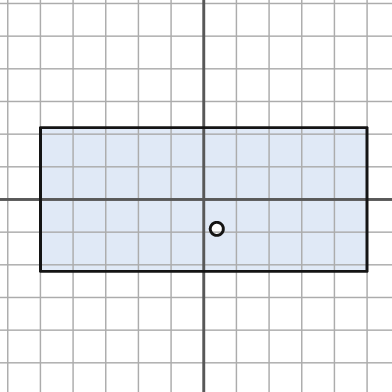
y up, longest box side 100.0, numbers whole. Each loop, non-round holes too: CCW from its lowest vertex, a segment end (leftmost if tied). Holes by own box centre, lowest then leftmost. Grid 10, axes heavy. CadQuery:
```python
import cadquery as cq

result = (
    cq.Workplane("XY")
    .moveTo(-50.0, -22.0)
    .lineTo(50.0, -22.0)
    .lineTo(50.0, 22.0)
    .lineTo(-50.0, 22.0)
    .close()
    .moveTo(4.0, -9.0)
    .circle(2.0)
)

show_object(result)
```